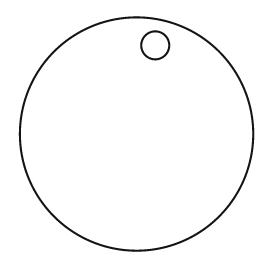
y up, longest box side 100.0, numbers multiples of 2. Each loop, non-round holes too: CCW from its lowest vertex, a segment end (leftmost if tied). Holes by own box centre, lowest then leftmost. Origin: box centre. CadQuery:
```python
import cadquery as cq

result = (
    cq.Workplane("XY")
    .moveTo(0.0, 0.0)
    .circle(50.0)
    .moveTo(8.0, 38.0)
    .circle(6.0)
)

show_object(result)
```